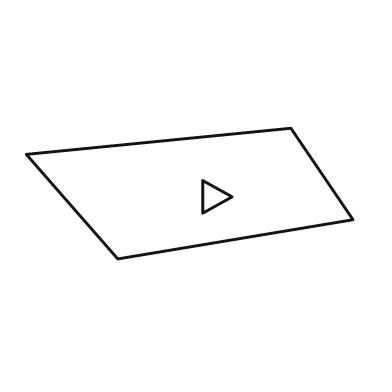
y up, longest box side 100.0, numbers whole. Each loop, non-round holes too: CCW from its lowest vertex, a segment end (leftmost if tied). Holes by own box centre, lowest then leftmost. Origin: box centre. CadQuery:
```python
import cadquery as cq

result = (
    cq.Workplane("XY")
    .moveTo(-22.0, -20.0)
    .lineTo(50.0, -8.0)
    .lineTo(31.0, 20.0)
    .lineTo(-50.0, 12.0)
    .close()
    .moveTo(4.0, -6.0)
    .lineTo(13.0, -1.0)
    .lineTo(4.0, 4.0)
    .close()
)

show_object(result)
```